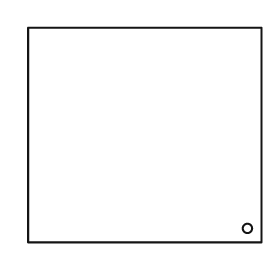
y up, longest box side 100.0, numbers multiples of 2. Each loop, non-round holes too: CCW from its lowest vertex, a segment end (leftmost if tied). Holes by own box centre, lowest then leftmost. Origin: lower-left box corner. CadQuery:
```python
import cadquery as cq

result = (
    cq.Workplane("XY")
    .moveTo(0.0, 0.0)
    .lineTo(100.0, 0.0)
    .lineTo(100.0, 92.0)
    .lineTo(0.0, 92.0)
    .close()
    .moveTo(94.0, 6.0)
    .circle(2.0)
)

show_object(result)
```